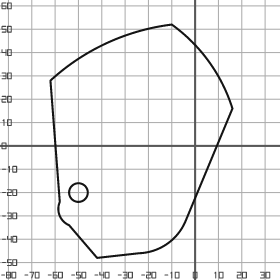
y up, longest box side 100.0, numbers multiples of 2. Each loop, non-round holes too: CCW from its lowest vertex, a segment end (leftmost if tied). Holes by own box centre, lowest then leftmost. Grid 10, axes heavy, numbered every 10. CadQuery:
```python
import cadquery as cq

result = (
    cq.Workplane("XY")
    .moveTo(-42.0, -48.0)
    .lineTo(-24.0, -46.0)
    .threePointArc((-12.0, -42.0), (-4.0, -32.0))
    .lineTo(16.0, 16.0)
    .threePointArc((6.0, 36.0), (-10.0, 52.0))
    .threePointArc((-38.0, 44.0), (-62.0, 28.0))
    .lineTo(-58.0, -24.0)
    .threePointArc((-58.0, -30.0), (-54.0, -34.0))
    .close()
    .moveTo(-50.0, -20.0)
    .circle(4.0)
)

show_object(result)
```